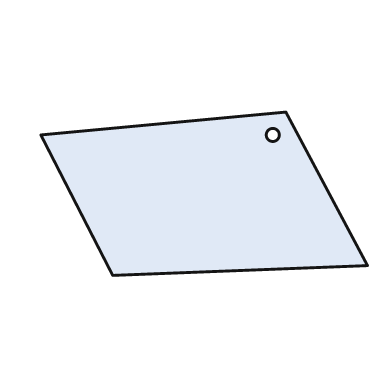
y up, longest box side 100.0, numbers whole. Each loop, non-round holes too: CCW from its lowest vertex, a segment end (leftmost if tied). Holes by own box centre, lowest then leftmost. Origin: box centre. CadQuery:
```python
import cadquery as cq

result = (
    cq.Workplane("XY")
    .moveTo(-28.0, -25.0)
    .lineTo(50.0, -22.0)
    .lineTo(25.0, 25.0)
    .lineTo(-50.0, 18.0)
    .close()
    .moveTo(21.0, 18.0)
    .circle(2.0)
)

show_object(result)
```